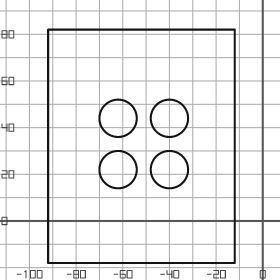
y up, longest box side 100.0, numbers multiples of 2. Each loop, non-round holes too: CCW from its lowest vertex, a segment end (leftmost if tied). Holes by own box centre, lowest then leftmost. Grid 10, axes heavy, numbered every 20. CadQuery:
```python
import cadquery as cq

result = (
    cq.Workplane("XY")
    .moveTo(-92.0, -18.0)
    .lineTo(-12.0, -18.0)
    .lineTo(-12.0, 82.0)
    .lineTo(-92.0, 82.0)
    .close()
    .moveTo(-62.0, 22.0)
    .circle(8.0)
    .moveTo(-40.0, 22.0)
    .circle(8.0)
    .moveTo(-62.0, 44.0)
    .circle(8.0)
    .moveTo(-40.0, 44.0)
    .circle(8.0)
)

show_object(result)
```